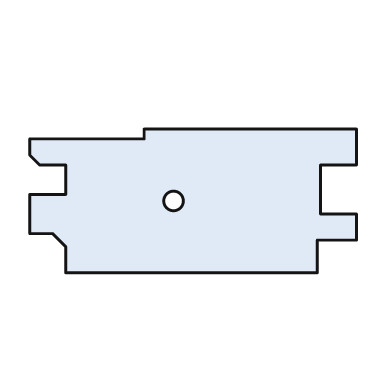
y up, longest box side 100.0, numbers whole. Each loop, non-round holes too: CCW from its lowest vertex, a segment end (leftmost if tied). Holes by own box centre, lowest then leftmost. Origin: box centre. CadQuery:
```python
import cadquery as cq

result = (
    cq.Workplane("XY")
    .moveTo(-39.0, -22.0)
    .lineTo(38.0, -22.0)
    .lineTo(38.0, -12.0)
    .lineTo(50.0, -12.0)
    .lineTo(50.0, -4.0)
    .lineTo(39.0, -4.0)
    .lineTo(39.0, 11.0)
    .lineTo(50.0, 11.0)
    .lineTo(50.0, 22.0)
    .lineTo(-15.0, 22.0)
    .lineTo(-15.0, 19.0)
    .lineTo(-50.0, 19.0)
    .lineTo(-50.0, 14.0)
    .lineTo(-47.0, 11.0)
    .lineTo(-39.0, 11.0)
    .lineTo(-39.0, 2.0)
    .lineTo(-50.0, 2.0)
    .lineTo(-50.0, -10.0)
    .lineTo(-43.0, -10.0)
    .lineTo(-39.0, -14.0)
    .close()
    .moveTo(-6.0, 0.0)
    .circle(3.0)
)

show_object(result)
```